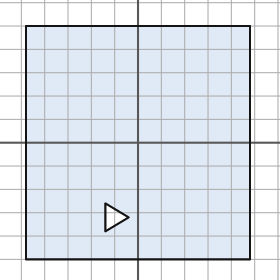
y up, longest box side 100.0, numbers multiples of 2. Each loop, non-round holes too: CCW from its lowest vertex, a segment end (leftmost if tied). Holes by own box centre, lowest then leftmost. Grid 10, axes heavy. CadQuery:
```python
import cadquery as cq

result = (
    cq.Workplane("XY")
    .moveTo(-48.0, -50.0)
    .lineTo(48.0, -50.0)
    .lineTo(48.0, 50.0)
    .lineTo(-48.0, 50.0)
    .close()
    .moveTo(-14.0, -38.0)
    .lineTo(-4.0, -32.0)
    .lineTo(-14.0, -26.0)
    .close()
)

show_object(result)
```